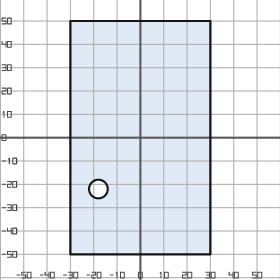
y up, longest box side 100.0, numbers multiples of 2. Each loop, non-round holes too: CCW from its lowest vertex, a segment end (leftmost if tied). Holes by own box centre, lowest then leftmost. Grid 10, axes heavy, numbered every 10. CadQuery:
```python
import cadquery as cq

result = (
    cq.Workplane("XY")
    .moveTo(-30.0, -50.0)
    .lineTo(30.0, -50.0)
    .lineTo(30.0, 50.0)
    .lineTo(-30.0, 50.0)
    .close()
    .moveTo(-18.0, -22.0)
    .circle(4.0)
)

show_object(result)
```